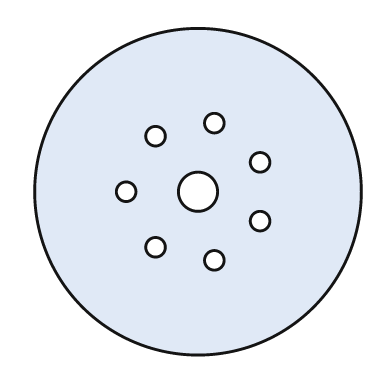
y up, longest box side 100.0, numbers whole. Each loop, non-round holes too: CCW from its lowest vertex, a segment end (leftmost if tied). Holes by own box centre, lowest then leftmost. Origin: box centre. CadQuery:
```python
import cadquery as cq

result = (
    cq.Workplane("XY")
    .moveTo(0.0, 0.0)
    .circle(50.0)
    .moveTo(5.0, -21.0)
    .circle(3.0)
    .moveTo(-13.0, -17.0)
    .circle(3.0)
    .moveTo(19.0, -9.0)
    .circle(3.0)
    .moveTo(-22.0, 0.0)
    .circle(3.0)
    .moveTo(0.0, 0.0)
    .circle(6.0)
    .moveTo(19.0, 9.0)
    .circle(3.0)
    .moveTo(-13.0, 17.0)
    .circle(3.0)
    .moveTo(5.0, 21.0)
    .circle(3.0)
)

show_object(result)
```